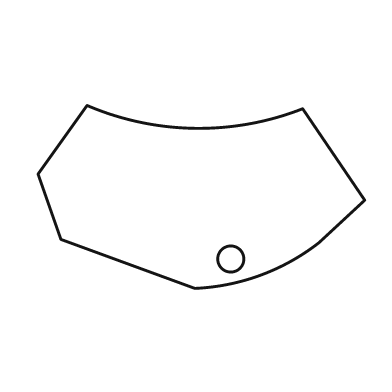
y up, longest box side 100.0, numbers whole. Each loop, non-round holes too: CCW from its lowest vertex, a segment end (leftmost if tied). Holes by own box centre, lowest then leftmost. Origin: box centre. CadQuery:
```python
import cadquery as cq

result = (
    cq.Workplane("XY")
    .moveTo(-2.0, -28.0)
    .threePointArc((18.0, -24.0), (36.0, -14.0))
    .lineTo(50.0, -1.0)
    .lineTo(31.0, 27.0)
    .threePointArc((-2.0, 21.0), (-35.0, 28.0))
    .lineTo(-50.0, 7.0)
    .lineTo(-43.0, -13.0)
    .close()
    .moveTo(9.0, -19.0)
    .circle(4.0)
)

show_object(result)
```